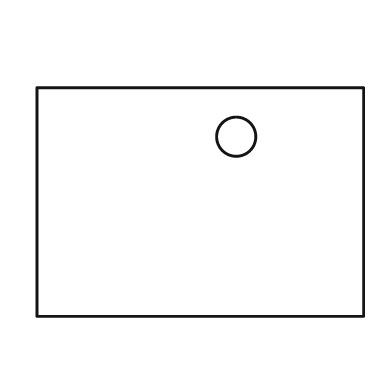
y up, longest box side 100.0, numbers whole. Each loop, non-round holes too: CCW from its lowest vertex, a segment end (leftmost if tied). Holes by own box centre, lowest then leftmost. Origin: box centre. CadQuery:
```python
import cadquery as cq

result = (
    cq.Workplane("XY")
    .moveTo(-50.0, -35.0)
    .lineTo(50.0, -35.0)
    .lineTo(50.0, 35.0)
    .lineTo(-50.0, 35.0)
    .close()
    .moveTo(11.0, 20.0)
    .circle(6.0)
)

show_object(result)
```